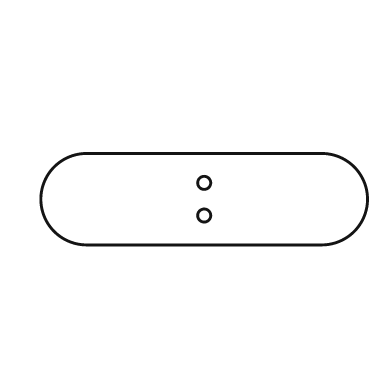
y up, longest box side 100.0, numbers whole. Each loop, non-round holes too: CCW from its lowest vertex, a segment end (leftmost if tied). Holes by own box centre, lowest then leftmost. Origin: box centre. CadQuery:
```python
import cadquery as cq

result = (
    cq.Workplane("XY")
    .moveTo(-36.0, -14.0)
    .lineTo(36.0, -14.0)
    .threePointArc((50.0, 0.0), (36.0, 14.0))
    .lineTo(-36.0, 14.0)
    .threePointArc((-50.0, 0.0), (-36.0, -14.0))
    .close()
    .moveTo(0.0, -5.0)
    .circle(2.0)
    .moveTo(0.0, 5.0)
    .circle(2.0)
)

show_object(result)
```